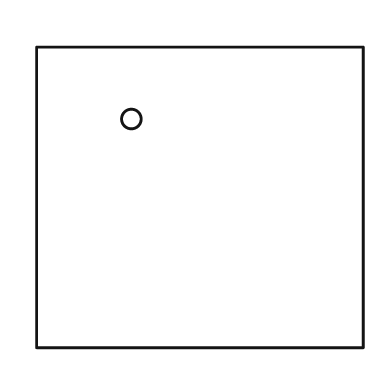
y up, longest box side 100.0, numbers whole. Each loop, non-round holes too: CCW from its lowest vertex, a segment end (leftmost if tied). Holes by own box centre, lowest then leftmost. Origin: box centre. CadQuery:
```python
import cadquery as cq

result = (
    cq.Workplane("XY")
    .moveTo(-50.0, -46.0)
    .lineTo(50.0, -46.0)
    .lineTo(50.0, 46.0)
    .lineTo(-50.0, 46.0)
    .close()
    .moveTo(-21.0, 24.0)
    .circle(3.0)
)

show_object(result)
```